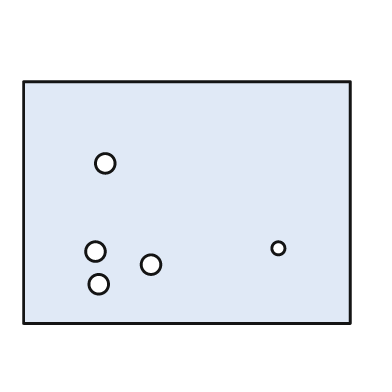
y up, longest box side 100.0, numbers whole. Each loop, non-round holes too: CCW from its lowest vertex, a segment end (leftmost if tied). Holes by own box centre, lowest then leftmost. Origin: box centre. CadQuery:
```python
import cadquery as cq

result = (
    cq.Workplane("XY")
    .moveTo(-50.0, -37.0)
    .lineTo(50.0, -37.0)
    .lineTo(50.0, 37.0)
    .lineTo(-50.0, 37.0)
    .close()
    .moveTo(-27.0, -25.0)
    .circle(3.0)
    .moveTo(-11.0, -19.0)
    .circle(3.0)
    .moveTo(-28.0, -15.0)
    .circle(3.0)
    .moveTo(28.0, -14.0)
    .circle(2.0)
    .moveTo(-25.0, 12.0)
    .circle(3.0)
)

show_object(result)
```